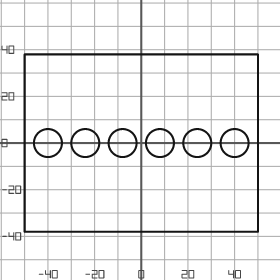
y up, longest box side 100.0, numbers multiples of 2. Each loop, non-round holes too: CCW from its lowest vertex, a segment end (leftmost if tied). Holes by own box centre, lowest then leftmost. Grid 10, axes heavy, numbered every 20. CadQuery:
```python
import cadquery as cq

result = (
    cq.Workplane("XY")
    .moveTo(-50.0, -38.0)
    .lineTo(50.0, -38.0)
    .lineTo(50.0, 38.0)
    .lineTo(-50.0, 38.0)
    .close()
    .moveTo(-40.0, 0.0)
    .circle(6.0)
    .moveTo(-24.0, 0.0)
    .circle(6.0)
    .moveTo(-8.0, 0.0)
    .circle(6.0)
    .moveTo(8.0, 0.0)
    .circle(6.0)
    .moveTo(24.0, 0.0)
    .circle(6.0)
    .moveTo(40.0, 0.0)
    .circle(6.0)
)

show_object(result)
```